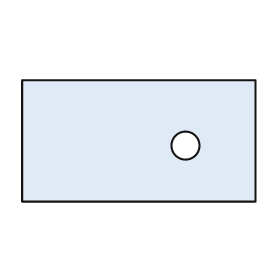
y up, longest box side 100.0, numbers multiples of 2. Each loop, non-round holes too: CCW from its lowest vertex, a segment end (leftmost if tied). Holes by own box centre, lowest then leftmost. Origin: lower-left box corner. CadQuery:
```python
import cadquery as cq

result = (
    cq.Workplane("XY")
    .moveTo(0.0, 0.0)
    .lineTo(100.0, 0.0)
    .lineTo(100.0, 52.0)
    .lineTo(0.0, 52.0)
    .close()
    .moveTo(70.0, 24.0)
    .circle(6.0)
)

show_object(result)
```